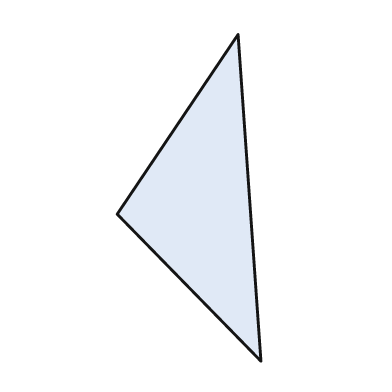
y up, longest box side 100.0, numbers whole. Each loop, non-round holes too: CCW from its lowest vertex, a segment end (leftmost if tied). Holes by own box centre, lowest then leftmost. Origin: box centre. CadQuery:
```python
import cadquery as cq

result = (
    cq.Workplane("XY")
    .moveTo(22.0, -50.0)
    .lineTo(15.0, 50.0)
    .lineTo(-22.0, -5.0)
    .close()
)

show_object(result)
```